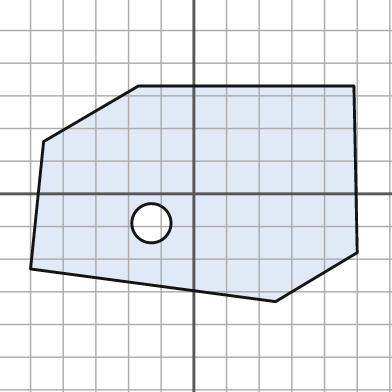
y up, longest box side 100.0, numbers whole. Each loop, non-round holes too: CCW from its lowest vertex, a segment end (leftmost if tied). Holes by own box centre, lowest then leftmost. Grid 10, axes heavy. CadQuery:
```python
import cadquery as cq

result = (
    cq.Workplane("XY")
    .moveTo(25.0, -33.0)
    .lineTo(50.0, -18.0)
    .lineTo(49.0, 33.0)
    .lineTo(-17.0, 33.0)
    .lineTo(-46.0, 16.0)
    .lineTo(-50.0, -23.0)
    .close()
    .moveTo(-13.0, -9.0)
    .circle(6.0)
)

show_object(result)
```